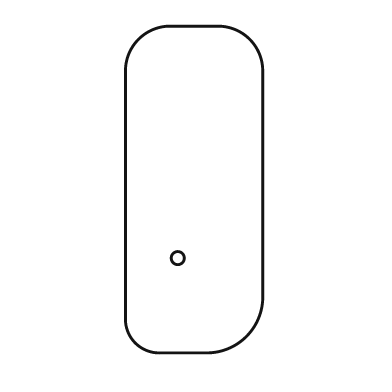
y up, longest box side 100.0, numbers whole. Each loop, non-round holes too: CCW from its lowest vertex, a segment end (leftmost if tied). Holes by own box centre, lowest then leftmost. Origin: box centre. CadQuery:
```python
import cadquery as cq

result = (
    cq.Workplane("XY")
    .moveTo(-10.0, -50.0)
    .lineTo(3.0, -50.0)
    .threePointArc((16.0, -45.0), (21.0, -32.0))
    .lineTo(21.0, 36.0)
    .threePointArc((17.0, 46.0), (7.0, 50.0))
    .lineTo(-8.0, 50.0)
    .threePointArc((-17.0, 46.0), (-21.0, 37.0))
    .lineTo(-21.0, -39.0)
    .threePointArc((-18.0, -47.0), (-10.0, -50.0))
    .close()
    .moveTo(-5.0, -21.0)
    .circle(2.0)
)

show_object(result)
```